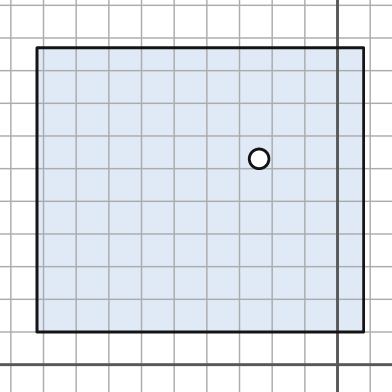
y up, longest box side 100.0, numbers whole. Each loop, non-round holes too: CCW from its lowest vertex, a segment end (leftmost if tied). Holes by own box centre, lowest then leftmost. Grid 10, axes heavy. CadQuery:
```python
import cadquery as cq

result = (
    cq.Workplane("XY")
    .moveTo(-92.0, 10.0)
    .lineTo(8.0, 10.0)
    .lineTo(8.0, 97.0)
    .lineTo(-92.0, 97.0)
    .close()
    .moveTo(-24.0, 63.0)
    .circle(3.0)
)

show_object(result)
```